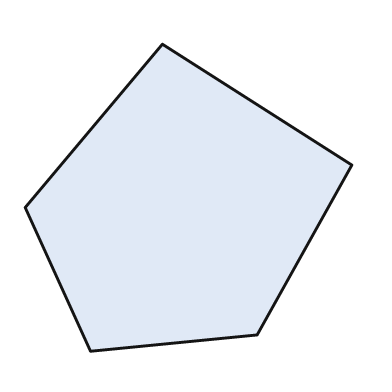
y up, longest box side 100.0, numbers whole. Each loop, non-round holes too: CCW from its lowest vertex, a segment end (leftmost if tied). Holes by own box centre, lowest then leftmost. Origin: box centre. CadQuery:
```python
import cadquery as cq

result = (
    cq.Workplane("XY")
    .moveTo(-30.0, -47.0)
    .lineTo(21.0, -42.0)
    .lineTo(50.0, 10.0)
    .lineTo(-8.0, 47.0)
    .lineTo(-50.0, -3.0)
    .close()
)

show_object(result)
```